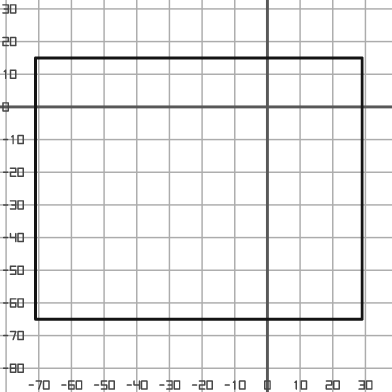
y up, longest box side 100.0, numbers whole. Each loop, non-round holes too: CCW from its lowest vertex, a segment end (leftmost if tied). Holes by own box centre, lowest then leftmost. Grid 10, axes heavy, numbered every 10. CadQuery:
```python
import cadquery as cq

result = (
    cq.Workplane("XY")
    .moveTo(-71.0, -65.0)
    .lineTo(29.0, -65.0)
    .lineTo(29.0, 15.0)
    .lineTo(-71.0, 15.0)
    .close()
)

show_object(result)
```